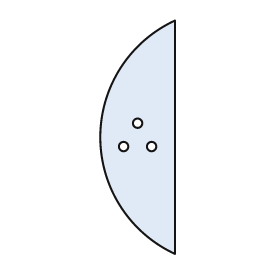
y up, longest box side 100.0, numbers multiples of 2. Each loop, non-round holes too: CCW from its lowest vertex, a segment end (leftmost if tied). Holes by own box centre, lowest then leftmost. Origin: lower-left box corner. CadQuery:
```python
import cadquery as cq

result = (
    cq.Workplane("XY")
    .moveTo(32.0, 0.0)
    .lineTo(32.0, 100.0)
    .threePointArc((0.0, 50.0), (32.0, 0.0))
    .close()
    .moveTo(10.0, 46.0)
    .circle(2.0)
    .moveTo(22.0, 46.0)
    .circle(2.0)
    .moveTo(16.0, 56.0)
    .circle(2.0)
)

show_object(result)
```